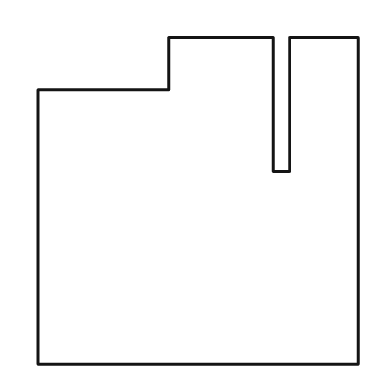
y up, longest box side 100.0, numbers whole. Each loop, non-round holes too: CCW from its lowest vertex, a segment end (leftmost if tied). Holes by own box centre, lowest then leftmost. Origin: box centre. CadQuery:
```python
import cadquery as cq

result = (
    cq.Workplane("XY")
    .moveTo(-49.0, -50.0)
    .lineTo(49.0, -50.0)
    .lineTo(49.0, 50.0)
    .lineTo(28.0, 50.0)
    .lineTo(28.0, 9.0)
    .lineTo(23.0, 9.0)
    .lineTo(23.0, 50.0)
    .lineTo(-9.0, 50.0)
    .lineTo(-9.0, 34.0)
    .lineTo(-49.0, 34.0)
    .close()
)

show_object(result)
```